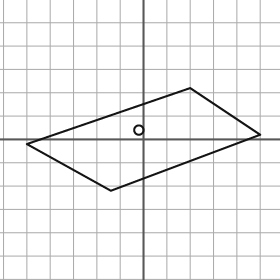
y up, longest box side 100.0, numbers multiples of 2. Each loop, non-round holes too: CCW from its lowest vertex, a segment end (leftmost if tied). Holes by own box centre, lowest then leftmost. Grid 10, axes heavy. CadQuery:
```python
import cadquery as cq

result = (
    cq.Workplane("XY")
    .moveTo(-14.0, -22.0)
    .lineTo(50.0, 2.0)
    .lineTo(20.0, 22.0)
    .lineTo(-50.0, -2.0)
    .close()
    .moveTo(-2.0, 4.0)
    .circle(2.0)
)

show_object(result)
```